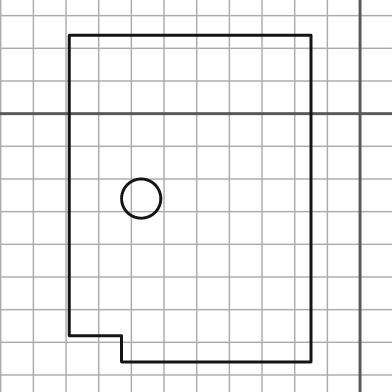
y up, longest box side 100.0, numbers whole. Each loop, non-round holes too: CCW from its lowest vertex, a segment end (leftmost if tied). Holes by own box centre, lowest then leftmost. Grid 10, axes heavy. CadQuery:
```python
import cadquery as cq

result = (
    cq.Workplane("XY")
    .moveTo(-73.0, -76.0)
    .lineTo(-15.0, -76.0)
    .lineTo(-15.0, 24.0)
    .lineTo(-89.0, 24.0)
    .lineTo(-89.0, -68.0)
    .lineTo(-73.0, -68.0)
    .close()
    .moveTo(-67.0, -26.0)
    .circle(6.0)
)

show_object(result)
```